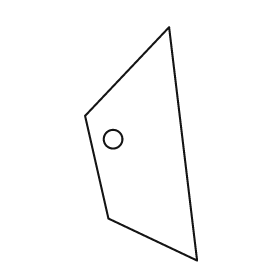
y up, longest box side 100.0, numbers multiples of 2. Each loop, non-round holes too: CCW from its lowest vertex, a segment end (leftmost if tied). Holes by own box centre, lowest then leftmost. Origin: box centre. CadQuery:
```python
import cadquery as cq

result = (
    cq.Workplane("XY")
    .moveTo(24.0, -50.0)
    .lineTo(12.0, 50.0)
    .lineTo(-24.0, 12.0)
    .lineTo(-14.0, -32.0)
    .close()
    .moveTo(-12.0, 2.0)
    .circle(4.0)
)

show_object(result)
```